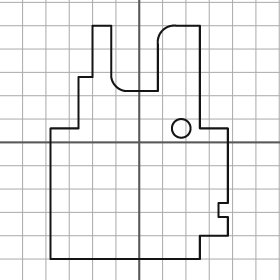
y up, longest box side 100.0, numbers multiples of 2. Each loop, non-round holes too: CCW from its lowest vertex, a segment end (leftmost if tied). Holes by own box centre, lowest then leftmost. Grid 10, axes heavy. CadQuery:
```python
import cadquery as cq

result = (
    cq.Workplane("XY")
    .moveTo(-38.0, -50.0)
    .lineTo(26.0, -50.0)
    .lineTo(26.0, -40.0)
    .lineTo(38.0, -40.0)
    .lineTo(38.0, -32.0)
    .lineTo(34.0, -32.0)
    .lineTo(34.0, -26.0)
    .lineTo(38.0, -26.0)
    .lineTo(38.0, 6.0)
    .lineTo(26.0, 6.0)
    .lineTo(26.0, 50.0)
    .lineTo(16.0, 50.0)
    .threePointArc((10.0, 48.0), (8.0, 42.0))
    .lineTo(8.0, 22.0)
    .lineTo(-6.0, 22.0)
    .threePointArc((-10.0, 24.0), (-12.0, 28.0))
    .lineTo(-12.0, 50.0)
    .lineTo(-20.0, 50.0)
    .lineTo(-20.0, 28.0)
    .lineTo(-26.0, 28.0)
    .lineTo(-26.0, 6.0)
    .lineTo(-38.0, 6.0)
    .close()
    .moveTo(18.0, 6.0)
    .circle(4.0)
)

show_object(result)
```